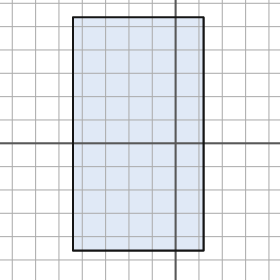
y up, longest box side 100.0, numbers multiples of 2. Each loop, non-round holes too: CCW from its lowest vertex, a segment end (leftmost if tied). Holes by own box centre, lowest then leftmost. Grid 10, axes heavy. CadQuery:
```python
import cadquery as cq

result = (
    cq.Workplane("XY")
    .moveTo(-44.0, -46.0)
    .lineTo(12.0, -46.0)
    .lineTo(12.0, 54.0)
    .lineTo(-44.0, 54.0)
    .close()
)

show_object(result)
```